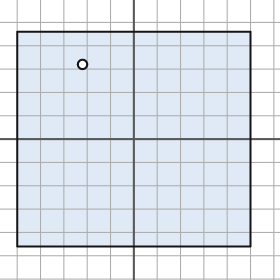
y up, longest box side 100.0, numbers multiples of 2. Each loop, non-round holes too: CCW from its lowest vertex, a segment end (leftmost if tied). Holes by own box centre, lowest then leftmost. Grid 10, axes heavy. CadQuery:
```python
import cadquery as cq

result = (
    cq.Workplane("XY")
    .moveTo(-50.0, -46.0)
    .lineTo(50.0, -46.0)
    .lineTo(50.0, 46.0)
    .lineTo(-50.0, 46.0)
    .close()
    .moveTo(-22.0, 32.0)
    .circle(2.0)
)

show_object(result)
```